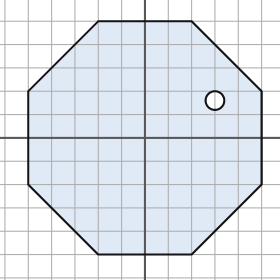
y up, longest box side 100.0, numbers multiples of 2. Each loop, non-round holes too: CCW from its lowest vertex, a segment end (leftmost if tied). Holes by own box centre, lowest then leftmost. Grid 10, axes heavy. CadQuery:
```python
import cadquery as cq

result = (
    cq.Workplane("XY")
    .moveTo(-20.0, -50.0)
    .lineTo(20.0, -50.0)
    .lineTo(50.0, -20.0)
    .lineTo(50.0, 20.0)
    .lineTo(20.0, 50.0)
    .lineTo(-20.0, 50.0)
    .lineTo(-50.0, 20.0)
    .lineTo(-50.0, -20.0)
    .close()
    .moveTo(30.0, 16.0)
    .circle(4.0)
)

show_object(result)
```